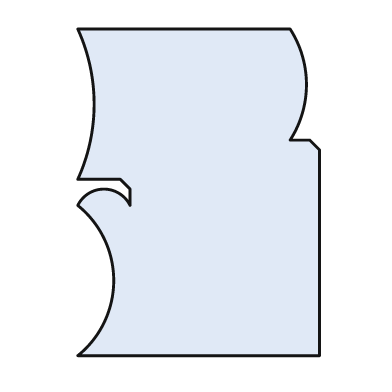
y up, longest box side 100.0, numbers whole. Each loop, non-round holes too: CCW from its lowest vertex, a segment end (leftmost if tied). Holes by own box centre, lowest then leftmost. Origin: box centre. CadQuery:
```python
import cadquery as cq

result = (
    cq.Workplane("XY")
    .moveTo(-37.0, -50.0)
    .lineTo(37.0, -50.0)
    .lineTo(37.0, 13.0)
    .lineTo(34.0, 16.0)
    .lineTo(28.0, 16.0)
    .threePointArc((33.0, 33.0), (28.0, 50.0))
    .lineTo(-37.0, 50.0)
    .threePointArc((-32.0, 27.0), (-37.0, 4.0))
    .lineTo(-24.0, 4.0)
    .lineTo(-21.0, 1.0)
    .lineTo(-21.0, -4.0)
    .threePointArc((-29.0, 1.0), (-37.0, -4.0))
    .threePointArc((-26.0, -27.0), (-37.0, -50.0))
    .close()
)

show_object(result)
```